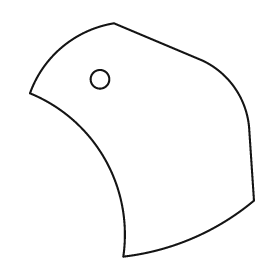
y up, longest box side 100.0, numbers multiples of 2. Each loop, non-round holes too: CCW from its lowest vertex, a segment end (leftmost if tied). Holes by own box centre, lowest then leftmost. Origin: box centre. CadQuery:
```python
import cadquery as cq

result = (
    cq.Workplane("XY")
    .moveTo(-8.0, -50.0)
    .threePointArc((22.0, -42.0), (48.0, -26.0))
    .lineTo(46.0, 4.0)
    .threePointArc((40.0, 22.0), (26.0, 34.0))
    .lineTo(-12.0, 50.0)
    .threePointArc((-34.0, 40.0), (-48.0, 20.0))
    .threePointArc((-16.0, -8.0), (-8.0, -50.0))
    .close()
    .moveTo(-18.0, 26.0)
    .circle(4.0)
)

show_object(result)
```